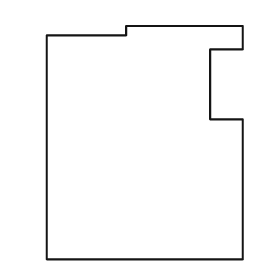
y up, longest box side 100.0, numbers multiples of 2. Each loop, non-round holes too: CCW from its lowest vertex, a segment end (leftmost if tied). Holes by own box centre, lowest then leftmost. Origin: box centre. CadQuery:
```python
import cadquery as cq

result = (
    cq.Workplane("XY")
    .moveTo(-42.0, -50.0)
    .lineTo(42.0, -50.0)
    .lineTo(42.0, 10.0)
    .lineTo(28.0, 10.0)
    .lineTo(28.0, 40.0)
    .lineTo(42.0, 40.0)
    .lineTo(42.0, 50.0)
    .lineTo(-8.0, 50.0)
    .lineTo(-8.0, 46.0)
    .lineTo(-42.0, 46.0)
    .close()
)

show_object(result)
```